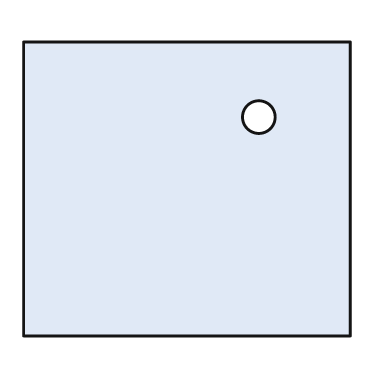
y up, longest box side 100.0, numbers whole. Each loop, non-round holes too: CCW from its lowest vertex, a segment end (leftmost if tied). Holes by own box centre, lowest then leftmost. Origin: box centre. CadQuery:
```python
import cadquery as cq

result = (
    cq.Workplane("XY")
    .moveTo(-50.0, -45.0)
    .lineTo(50.0, -45.0)
    .lineTo(50.0, 45.0)
    .lineTo(-50.0, 45.0)
    .close()
    .moveTo(22.0, 22.0)
    .circle(5.0)
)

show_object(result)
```